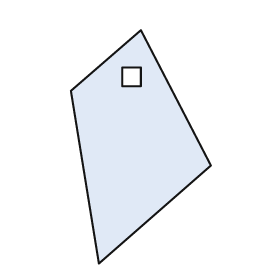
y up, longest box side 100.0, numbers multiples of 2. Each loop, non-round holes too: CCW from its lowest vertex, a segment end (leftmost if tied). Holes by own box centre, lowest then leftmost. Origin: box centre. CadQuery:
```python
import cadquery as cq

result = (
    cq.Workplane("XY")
    .moveTo(-18.0, -50.0)
    .lineTo(30.0, -8.0)
    .lineTo(0.0, 50.0)
    .lineTo(-30.0, 24.0)
    .close()
    .moveTo(-8.0, 26.0)
    .lineTo(0.0, 26.0)
    .lineTo(0.0, 34.0)
    .lineTo(-8.0, 34.0)
    .close()
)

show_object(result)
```